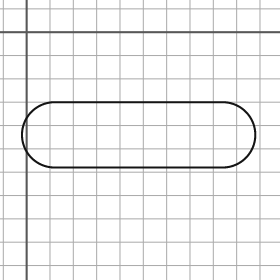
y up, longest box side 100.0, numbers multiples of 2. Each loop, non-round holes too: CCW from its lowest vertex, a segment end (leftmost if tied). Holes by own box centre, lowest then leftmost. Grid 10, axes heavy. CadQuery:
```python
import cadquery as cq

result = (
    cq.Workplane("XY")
    .moveTo(12.0, -58.0)
    .lineTo(84.0, -58.0)
    .threePointArc((98.0, -44.0), (84.0, -30.0))
    .lineTo(12.0, -30.0)
    .threePointArc((-2.0, -44.0), (12.0, -58.0))
    .close()
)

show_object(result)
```